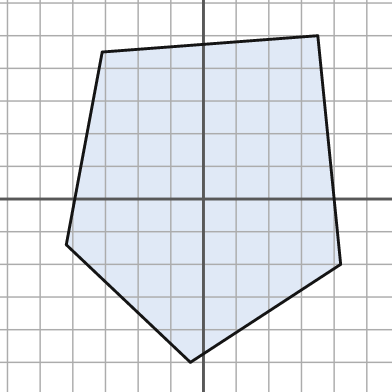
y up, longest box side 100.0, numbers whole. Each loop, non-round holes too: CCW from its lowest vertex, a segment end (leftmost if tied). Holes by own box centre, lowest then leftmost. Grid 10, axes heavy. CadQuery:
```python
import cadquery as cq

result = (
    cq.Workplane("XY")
    .moveTo(-4.0, -50.0)
    .lineTo(42.0, -20.0)
    .lineTo(35.0, 50.0)
    .lineTo(-31.0, 45.0)
    .lineTo(-42.0, -14.0)
    .close()
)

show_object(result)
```